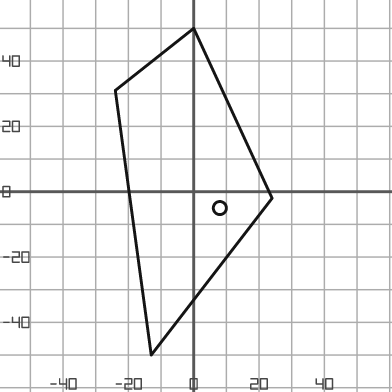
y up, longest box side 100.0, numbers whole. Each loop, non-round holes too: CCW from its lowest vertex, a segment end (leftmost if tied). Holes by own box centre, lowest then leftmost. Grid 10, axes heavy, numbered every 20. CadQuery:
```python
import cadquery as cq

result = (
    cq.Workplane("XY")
    .moveTo(-13.0, -50.0)
    .lineTo(24.0, -2.0)
    .lineTo(0.0, 50.0)
    .lineTo(-24.0, 31.0)
    .close()
    .moveTo(8.0, -5.0)
    .circle(2.0)
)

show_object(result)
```